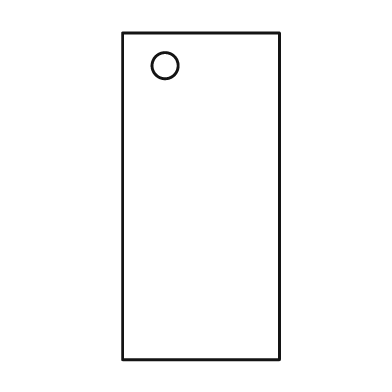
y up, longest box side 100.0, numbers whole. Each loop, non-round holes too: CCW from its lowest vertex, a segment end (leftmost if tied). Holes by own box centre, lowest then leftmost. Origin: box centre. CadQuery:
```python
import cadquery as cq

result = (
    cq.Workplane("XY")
    .moveTo(-24.0, -50.0)
    .lineTo(24.0, -50.0)
    .lineTo(24.0, 50.0)
    .lineTo(-24.0, 50.0)
    .close()
    .moveTo(-11.0, 40.0)
    .circle(4.0)
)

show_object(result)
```